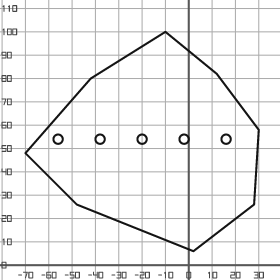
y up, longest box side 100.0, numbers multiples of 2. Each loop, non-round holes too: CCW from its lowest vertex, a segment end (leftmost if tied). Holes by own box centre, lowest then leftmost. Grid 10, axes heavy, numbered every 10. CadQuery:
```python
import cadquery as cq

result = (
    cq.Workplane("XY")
    .moveTo(2.0, 6.0)
    .lineTo(28.0, 26.0)
    .lineTo(30.0, 58.0)
    .lineTo(12.0, 82.0)
    .lineTo(-10.0, 100.0)
    .lineTo(-42.0, 80.0)
    .lineTo(-70.0, 48.0)
    .lineTo(-48.0, 26.0)
    .close()
    .moveTo(-56.0, 54.0)
    .circle(2.0)
    .moveTo(-38.0, 54.0)
    .circle(2.0)
    .moveTo(-20.0, 54.0)
    .circle(2.0)
    .moveTo(-2.0, 54.0)
    .circle(2.0)
    .moveTo(16.0, 54.0)
    .circle(2.0)
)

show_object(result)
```